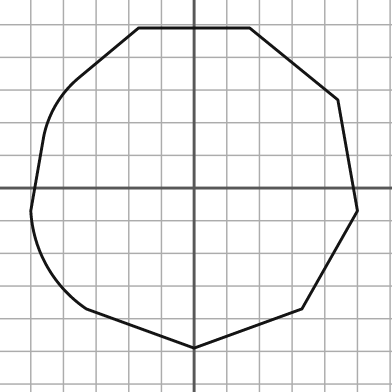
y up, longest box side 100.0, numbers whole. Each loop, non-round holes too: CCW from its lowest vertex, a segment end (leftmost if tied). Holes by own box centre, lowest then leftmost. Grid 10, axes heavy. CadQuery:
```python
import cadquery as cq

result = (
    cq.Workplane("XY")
    .moveTo(0.0, -49.0)
    .lineTo(33.0, -37.0)
    .lineTo(50.0, -7.0)
    .lineTo(44.0, 27.0)
    .lineTo(17.0, 49.0)
    .lineTo(-17.0, 49.0)
    .lineTo(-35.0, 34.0)
    .threePointArc((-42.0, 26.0), (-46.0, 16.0))
    .lineTo(-50.0, -7.0)
    .threePointArc((-45.0, -24.0), (-33.0, -37.0))
    .close()
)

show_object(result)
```